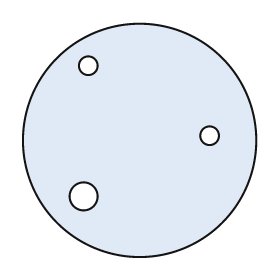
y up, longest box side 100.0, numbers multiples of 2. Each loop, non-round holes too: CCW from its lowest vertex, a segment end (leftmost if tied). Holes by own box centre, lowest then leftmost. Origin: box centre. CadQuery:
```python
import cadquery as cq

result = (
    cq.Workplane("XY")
    .moveTo(0.0, 0.0)
    .circle(50.0)
    .moveTo(-24.0, -24.0)
    .circle(6.0)
    .moveTo(30.0, 2.0)
    .circle(4.0)
    .moveTo(-22.0, 32.0)
    .circle(4.0)
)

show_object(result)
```